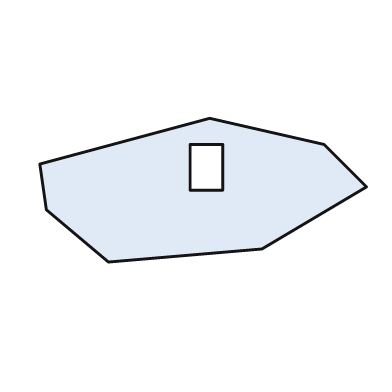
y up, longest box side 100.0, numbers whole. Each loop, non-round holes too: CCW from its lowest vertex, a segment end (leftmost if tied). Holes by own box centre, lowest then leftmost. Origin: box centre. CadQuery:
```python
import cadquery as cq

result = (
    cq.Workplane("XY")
    .moveTo(-29.0, -22.0)
    .lineTo(18.0, -18.0)
    .lineTo(50.0, 1.0)
    .lineTo(37.0, 14.0)
    .lineTo(2.0, 22.0)
    .lineTo(-50.0, 8.0)
    .lineTo(-48.0, -6.0)
    .close()
    .moveTo(-4.0, 0.0)
    .lineTo(6.0, 0.0)
    .lineTo(6.0, 14.0)
    .lineTo(-4.0, 14.0)
    .close()
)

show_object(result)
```